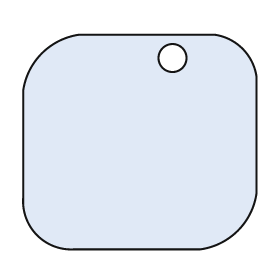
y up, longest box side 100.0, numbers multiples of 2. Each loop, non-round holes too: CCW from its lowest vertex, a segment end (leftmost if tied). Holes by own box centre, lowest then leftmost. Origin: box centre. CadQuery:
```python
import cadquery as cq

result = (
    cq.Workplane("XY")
    .moveTo(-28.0, -46.0)
    .lineTo(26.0, -46.0)
    .threePointArc((42.0, -38.0), (50.0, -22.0))
    .lineTo(50.0, 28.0)
    .threePointArc((44.0, 40.0), (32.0, 46.0))
    .lineTo(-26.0, 46.0)
    .threePointArc((-42.0, 38.0), (-50.0, 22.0))
    .lineTo(-50.0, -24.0)
    .threePointArc((-44.0, -40.0), (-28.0, -46.0))
    .close()
    .moveTo(14.0, 36.0)
    .circle(6.0)
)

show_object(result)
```